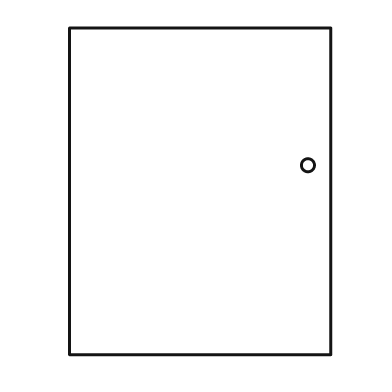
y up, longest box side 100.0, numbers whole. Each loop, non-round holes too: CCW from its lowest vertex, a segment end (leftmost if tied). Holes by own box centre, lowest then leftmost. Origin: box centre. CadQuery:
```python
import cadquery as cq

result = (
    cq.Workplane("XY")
    .moveTo(-40.0, -50.0)
    .lineTo(40.0, -50.0)
    .lineTo(40.0, 50.0)
    .lineTo(-40.0, 50.0)
    .close()
    .moveTo(33.0, 8.0)
    .circle(2.0)
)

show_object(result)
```